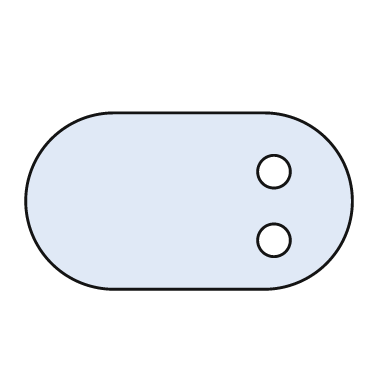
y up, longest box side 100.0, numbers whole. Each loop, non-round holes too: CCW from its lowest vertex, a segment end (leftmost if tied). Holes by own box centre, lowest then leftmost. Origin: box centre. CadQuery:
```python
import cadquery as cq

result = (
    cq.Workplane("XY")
    .moveTo(-23.0, -27.0)
    .lineTo(23.0, -27.0)
    .threePointArc((50.0, 0.0), (23.0, 27.0))
    .lineTo(-23.0, 27.0)
    .threePointArc((-50.0, 0.0), (-23.0, -27.0))
    .close()
    .moveTo(26.0, -12.0)
    .circle(5.0)
    .moveTo(26.0, 9.0)
    .circle(5.0)
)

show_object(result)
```